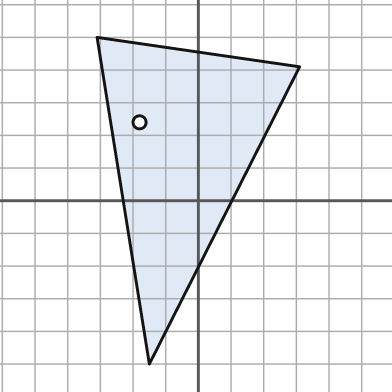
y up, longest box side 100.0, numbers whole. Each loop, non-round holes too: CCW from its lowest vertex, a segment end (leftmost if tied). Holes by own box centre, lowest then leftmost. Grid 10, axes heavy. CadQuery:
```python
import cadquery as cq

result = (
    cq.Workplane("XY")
    .moveTo(-15.0, -50.0)
    .lineTo(31.0, 41.0)
    .lineTo(-31.0, 50.0)
    .close()
    .moveTo(-18.0, 24.0)
    .circle(2.0)
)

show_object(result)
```